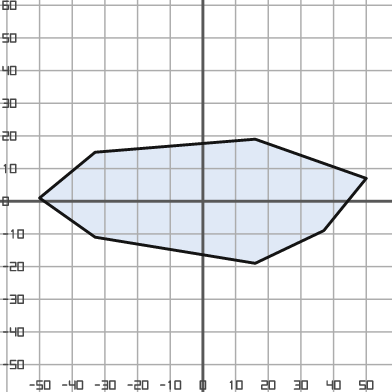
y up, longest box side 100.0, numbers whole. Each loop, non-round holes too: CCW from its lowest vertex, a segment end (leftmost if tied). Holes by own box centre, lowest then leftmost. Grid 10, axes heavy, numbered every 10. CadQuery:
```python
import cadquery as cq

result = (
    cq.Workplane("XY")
    .moveTo(16.0, -19.0)
    .lineTo(37.0, -9.0)
    .lineTo(50.0, 7.0)
    .lineTo(16.0, 19.0)
    .lineTo(-33.0, 15.0)
    .lineTo(-50.0, 1.0)
    .lineTo(-33.0, -11.0)
    .close()
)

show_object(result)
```